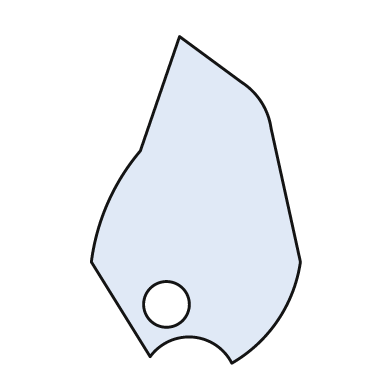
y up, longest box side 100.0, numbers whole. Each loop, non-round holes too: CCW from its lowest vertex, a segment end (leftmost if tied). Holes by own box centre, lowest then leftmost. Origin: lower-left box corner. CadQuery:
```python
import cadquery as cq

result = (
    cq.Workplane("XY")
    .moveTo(43.0, 0.0)
    .threePointArc((57.0, 13.0), (64.0, 31.0))
    .lineTo(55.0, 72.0)
    .threePointArc((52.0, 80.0), (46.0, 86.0))
    .lineTo(27.0, 100.0)
    .lineTo(15.0, 65.0)
    .threePointArc((5.0, 49.0), (0.0, 31.0))
    .lineTo(18.0, 2.0)
    .threePointArc((31.0, 8.0), (43.0, 0.0))
    .close()
    .moveTo(23.0, 18.0)
    .circle(7.0)
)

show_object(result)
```